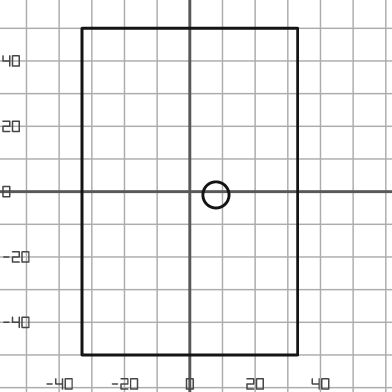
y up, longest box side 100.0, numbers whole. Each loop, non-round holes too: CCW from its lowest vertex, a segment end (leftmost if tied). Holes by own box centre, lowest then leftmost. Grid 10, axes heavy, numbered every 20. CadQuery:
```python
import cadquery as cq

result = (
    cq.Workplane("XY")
    .moveTo(-33.0, -50.0)
    .lineTo(33.0, -50.0)
    .lineTo(33.0, 50.0)
    .lineTo(-33.0, 50.0)
    .close()
    .moveTo(8.0, -1.0)
    .circle(4.0)
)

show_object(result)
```